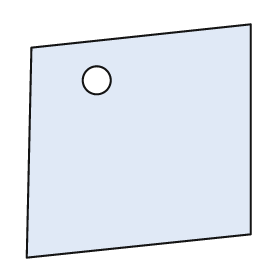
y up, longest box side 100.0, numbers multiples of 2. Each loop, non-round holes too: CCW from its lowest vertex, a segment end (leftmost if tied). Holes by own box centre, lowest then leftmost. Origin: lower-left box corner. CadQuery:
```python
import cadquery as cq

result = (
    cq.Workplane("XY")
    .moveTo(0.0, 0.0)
    .lineTo(96.0, 10.0)
    .lineTo(96.0, 100.0)
    .lineTo(2.0, 90.0)
    .close()
    .moveTo(30.0, 76.0)
    .circle(6.0)
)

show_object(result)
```